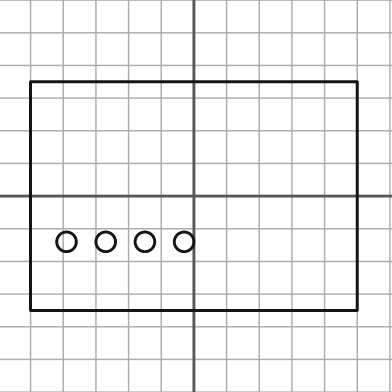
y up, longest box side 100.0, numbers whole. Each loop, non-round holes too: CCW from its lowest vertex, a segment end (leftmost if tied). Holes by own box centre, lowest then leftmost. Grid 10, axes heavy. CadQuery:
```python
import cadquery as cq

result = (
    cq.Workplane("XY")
    .moveTo(-50.0, -35.0)
    .lineTo(50.0, -35.0)
    .lineTo(50.0, 35.0)
    .lineTo(-50.0, 35.0)
    .close()
    .moveTo(-39.0, -14.0)
    .circle(3.0)
    .moveTo(-27.0, -14.0)
    .circle(3.0)
    .moveTo(-15.0, -14.0)
    .circle(3.0)
    .moveTo(-3.0, -14.0)
    .circle(3.0)
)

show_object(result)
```